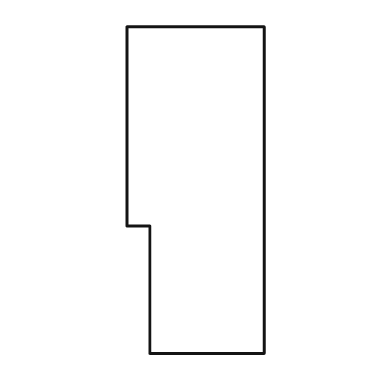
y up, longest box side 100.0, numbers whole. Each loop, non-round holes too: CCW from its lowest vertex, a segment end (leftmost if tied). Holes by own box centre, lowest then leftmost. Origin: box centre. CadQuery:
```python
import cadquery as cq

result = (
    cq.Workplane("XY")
    .moveTo(-14.0, -50.0)
    .lineTo(21.0, -50.0)
    .lineTo(21.0, 50.0)
    .lineTo(-21.0, 50.0)
    .lineTo(-21.0, -11.0)
    .lineTo(-14.0, -11.0)
    .close()
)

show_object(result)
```